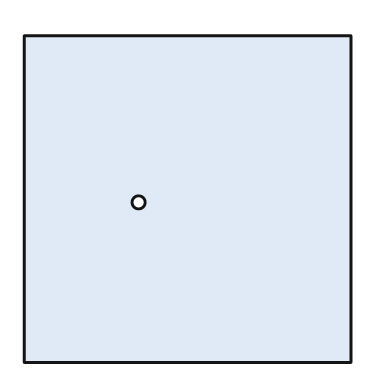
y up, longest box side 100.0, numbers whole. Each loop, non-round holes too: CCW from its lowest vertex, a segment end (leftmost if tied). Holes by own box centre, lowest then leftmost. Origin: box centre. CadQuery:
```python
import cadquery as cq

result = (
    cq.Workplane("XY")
    .moveTo(-50.0, -50.0)
    .lineTo(50.0, -50.0)
    .lineTo(50.0, 50.0)
    .lineTo(-50.0, 50.0)
    .close()
    .moveTo(-15.0, -1.0)
    .circle(2.0)
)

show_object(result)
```